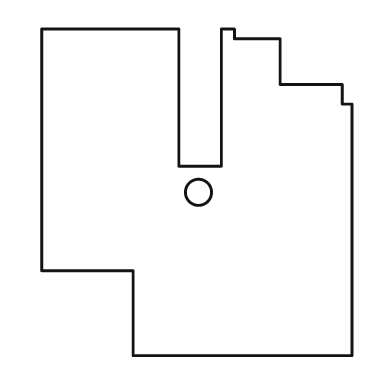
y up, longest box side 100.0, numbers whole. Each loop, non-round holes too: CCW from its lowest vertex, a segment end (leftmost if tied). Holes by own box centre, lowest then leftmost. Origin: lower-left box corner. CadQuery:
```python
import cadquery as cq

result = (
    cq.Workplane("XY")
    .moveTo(28.0, 0.0)
    .lineTo(95.0, 0.0)
    .lineTo(95.0, 77.0)
    .lineTo(92.0, 77.0)
    .lineTo(92.0, 83.0)
    .lineTo(73.0, 83.0)
    .lineTo(73.0, 97.0)
    .lineTo(59.0, 97.0)
    .lineTo(59.0, 100.0)
    .lineTo(55.0, 100.0)
    .lineTo(55.0, 58.0)
    .lineTo(42.0, 58.0)
    .lineTo(42.0, 100.0)
    .lineTo(0.0, 100.0)
    .lineTo(0.0, 26.0)
    .lineTo(28.0, 26.0)
    .close()
    .moveTo(48.0, 50.0)
    .circle(4.0)
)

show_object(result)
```